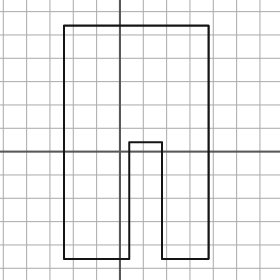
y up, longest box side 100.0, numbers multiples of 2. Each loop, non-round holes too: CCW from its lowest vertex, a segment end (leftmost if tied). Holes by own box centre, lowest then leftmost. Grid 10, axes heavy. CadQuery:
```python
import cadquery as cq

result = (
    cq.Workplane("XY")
    .moveTo(-24.0, -46.0)
    .lineTo(4.0, -46.0)
    .lineTo(4.0, 4.0)
    .lineTo(18.0, 4.0)
    .lineTo(18.0, -46.0)
    .lineTo(38.0, -46.0)
    .lineTo(38.0, 54.0)
    .lineTo(-24.0, 54.0)
    .close()
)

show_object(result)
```